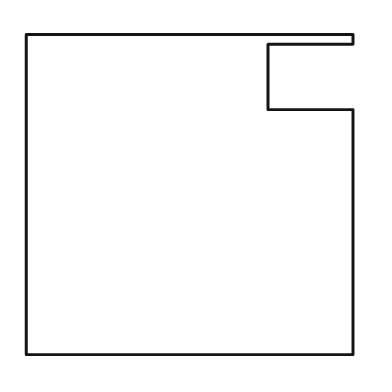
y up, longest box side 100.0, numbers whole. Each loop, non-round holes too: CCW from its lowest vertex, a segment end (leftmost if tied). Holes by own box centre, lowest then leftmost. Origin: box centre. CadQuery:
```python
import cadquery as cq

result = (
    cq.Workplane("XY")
    .moveTo(-50.0, -49.0)
    .lineTo(50.0, -49.0)
    .lineTo(50.0, 26.0)
    .lineTo(24.0, 26.0)
    .lineTo(24.0, 46.0)
    .lineTo(50.0, 46.0)
    .lineTo(50.0, 49.0)
    .lineTo(-50.0, 49.0)
    .close()
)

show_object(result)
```